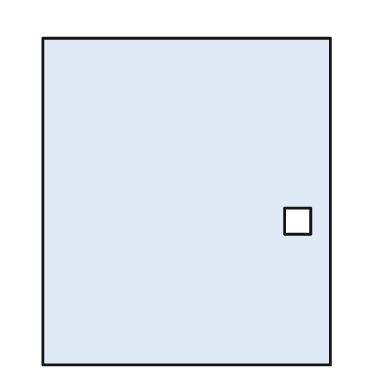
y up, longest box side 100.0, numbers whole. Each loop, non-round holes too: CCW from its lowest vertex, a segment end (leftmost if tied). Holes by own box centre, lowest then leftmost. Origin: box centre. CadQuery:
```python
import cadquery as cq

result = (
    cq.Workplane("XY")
    .moveTo(-44.0, -50.0)
    .lineTo(44.0, -50.0)
    .lineTo(44.0, 50.0)
    .lineTo(-44.0, 50.0)
    .close()
    .moveTo(30.0, -10.0)
    .lineTo(38.0, -10.0)
    .lineTo(38.0, -2.0)
    .lineTo(30.0, -2.0)
    .close()
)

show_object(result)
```